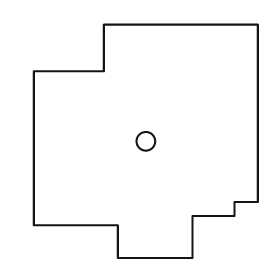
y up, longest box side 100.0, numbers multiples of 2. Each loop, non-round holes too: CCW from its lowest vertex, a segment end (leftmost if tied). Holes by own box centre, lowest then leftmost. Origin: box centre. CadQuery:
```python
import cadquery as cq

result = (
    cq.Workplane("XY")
    .moveTo(-12.0, -50.0)
    .lineTo(20.0, -50.0)
    .lineTo(20.0, -32.0)
    .lineTo(38.0, -32.0)
    .lineTo(38.0, -26.0)
    .lineTo(48.0, -26.0)
    .lineTo(48.0, 50.0)
    .lineTo(-18.0, 50.0)
    .lineTo(-18.0, 30.0)
    .lineTo(-48.0, 30.0)
    .lineTo(-48.0, -36.0)
    .lineTo(-12.0, -36.0)
    .close()
    .moveTo(0.0, 0.0)
    .circle(4.0)
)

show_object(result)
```